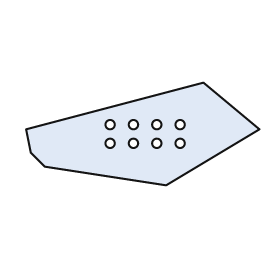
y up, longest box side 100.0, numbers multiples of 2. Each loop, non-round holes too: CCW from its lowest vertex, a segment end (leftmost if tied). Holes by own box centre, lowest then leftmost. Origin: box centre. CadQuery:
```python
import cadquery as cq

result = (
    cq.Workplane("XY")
    .moveTo(10.0, -22.0)
    .lineTo(50.0, 2.0)
    .lineTo(26.0, 22.0)
    .lineTo(-50.0, 2.0)
    .lineTo(-48.0, -8.0)
    .lineTo(-42.0, -14.0)
    .close()
    .moveTo(-14.0, -4.0)
    .circle(2.0)
    .moveTo(-4.0, -4.0)
    .circle(2.0)
    .moveTo(6.0, -4.0)
    .circle(2.0)
    .moveTo(16.0, -4.0)
    .circle(2.0)
    .moveTo(-14.0, 4.0)
    .circle(2.0)
    .moveTo(-4.0, 4.0)
    .circle(2.0)
    .moveTo(6.0, 4.0)
    .circle(2.0)
    .moveTo(16.0, 4.0)
    .circle(2.0)
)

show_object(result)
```